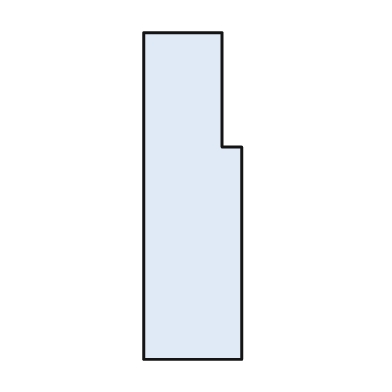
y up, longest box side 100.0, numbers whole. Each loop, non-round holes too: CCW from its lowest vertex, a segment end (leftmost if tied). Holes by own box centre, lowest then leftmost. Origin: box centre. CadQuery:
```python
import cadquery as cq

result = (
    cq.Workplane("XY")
    .moveTo(-15.0, -50.0)
    .lineTo(15.0, -50.0)
    .lineTo(15.0, 15.0)
    .lineTo(9.0, 15.0)
    .lineTo(9.0, 50.0)
    .lineTo(-15.0, 50.0)
    .close()
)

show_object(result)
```